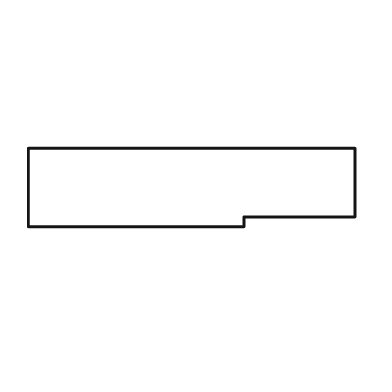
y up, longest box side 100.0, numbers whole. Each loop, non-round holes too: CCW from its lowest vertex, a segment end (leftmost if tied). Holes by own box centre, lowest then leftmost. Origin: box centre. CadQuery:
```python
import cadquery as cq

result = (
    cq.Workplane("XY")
    .moveTo(-50.0, -12.0)
    .lineTo(16.0, -12.0)
    .lineTo(16.0, -9.0)
    .lineTo(50.0, -9.0)
    .lineTo(50.0, 12.0)
    .lineTo(-50.0, 12.0)
    .close()
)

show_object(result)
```